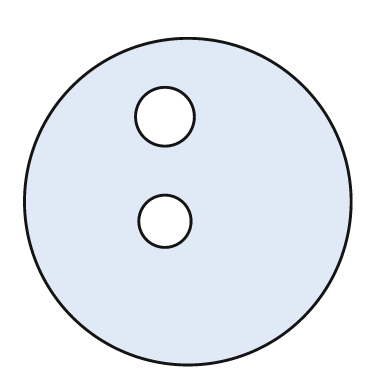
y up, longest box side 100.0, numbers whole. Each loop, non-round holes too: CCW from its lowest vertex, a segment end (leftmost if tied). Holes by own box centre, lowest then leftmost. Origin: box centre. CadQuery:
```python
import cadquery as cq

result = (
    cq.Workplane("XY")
    .moveTo(0.0, 0.0)
    .circle(50.0)
    .moveTo(-7.0, -6.0)
    .circle(8.0)
    .moveTo(-7.0, 26.0)
    .circle(9.0)
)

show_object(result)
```